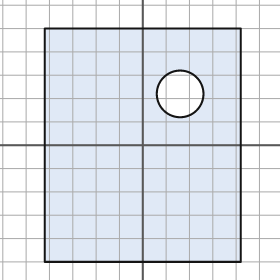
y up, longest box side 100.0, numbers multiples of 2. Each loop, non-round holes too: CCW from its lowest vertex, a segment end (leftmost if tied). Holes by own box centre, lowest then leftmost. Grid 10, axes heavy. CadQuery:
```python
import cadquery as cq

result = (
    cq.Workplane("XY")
    .moveTo(-42.0, -50.0)
    .lineTo(42.0, -50.0)
    .lineTo(42.0, 50.0)
    .lineTo(-42.0, 50.0)
    .close()
    .moveTo(16.0, 22.0)
    .circle(10.0)
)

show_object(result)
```